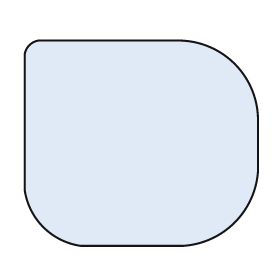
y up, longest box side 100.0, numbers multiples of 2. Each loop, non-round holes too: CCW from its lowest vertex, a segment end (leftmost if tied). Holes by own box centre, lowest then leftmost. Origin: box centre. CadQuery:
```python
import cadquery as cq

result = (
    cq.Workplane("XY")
    .moveTo(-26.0, -44.0)
    .lineTo(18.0, -44.0)
    .threePointArc((40.0, -34.0), (50.0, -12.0))
    .lineTo(50.0, 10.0)
    .threePointArc((40.0, 34.0), (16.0, 44.0))
    .lineTo(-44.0, 44.0)
    .threePointArc((-48.0, 42.0), (-50.0, 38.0))
    .lineTo(-50.0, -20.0)
    .threePointArc((-42.0, -36.0), (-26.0, -44.0))
    .close()
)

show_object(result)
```